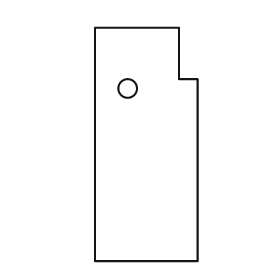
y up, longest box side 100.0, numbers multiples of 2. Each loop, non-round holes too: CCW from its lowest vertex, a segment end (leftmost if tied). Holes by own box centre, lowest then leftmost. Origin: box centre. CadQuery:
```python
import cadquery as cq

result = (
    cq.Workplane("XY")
    .moveTo(-22.0, -50.0)
    .lineTo(22.0, -50.0)
    .lineTo(22.0, 28.0)
    .lineTo(14.0, 28.0)
    .lineTo(14.0, 50.0)
    .lineTo(-22.0, 50.0)
    .close()
    .moveTo(-8.0, 24.0)
    .circle(4.0)
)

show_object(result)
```